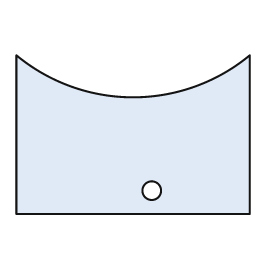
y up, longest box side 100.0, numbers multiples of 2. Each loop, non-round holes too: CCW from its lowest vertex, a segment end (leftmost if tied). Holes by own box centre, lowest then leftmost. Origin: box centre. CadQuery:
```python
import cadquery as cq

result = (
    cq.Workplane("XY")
    .moveTo(-50.0, -34.0)
    .lineTo(50.0, -34.0)
    .lineTo(50.0, 34.0)
    .threePointArc((0.0, 16.0), (-50.0, 34.0))
    .close()
    .moveTo(8.0, -24.0)
    .circle(4.0)
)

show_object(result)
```